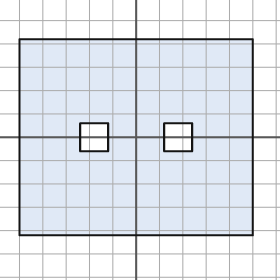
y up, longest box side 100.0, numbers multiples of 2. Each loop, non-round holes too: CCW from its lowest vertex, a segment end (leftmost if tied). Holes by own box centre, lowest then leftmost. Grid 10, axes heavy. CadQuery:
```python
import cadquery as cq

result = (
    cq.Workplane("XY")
    .moveTo(-50.0, -42.0)
    .lineTo(50.0, -42.0)
    .lineTo(50.0, 42.0)
    .lineTo(-50.0, 42.0)
    .close()
    .moveTo(-24.0, -6.0)
    .lineTo(-12.0, -6.0)
    .lineTo(-12.0, 6.0)
    .lineTo(-24.0, 6.0)
    .close()
    .moveTo(12.0, -6.0)
    .lineTo(24.0, -6.0)
    .lineTo(24.0, 6.0)
    .lineTo(12.0, 6.0)
    .close()
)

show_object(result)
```